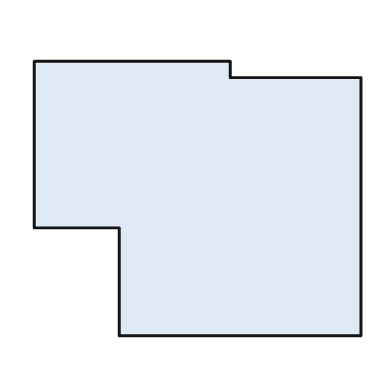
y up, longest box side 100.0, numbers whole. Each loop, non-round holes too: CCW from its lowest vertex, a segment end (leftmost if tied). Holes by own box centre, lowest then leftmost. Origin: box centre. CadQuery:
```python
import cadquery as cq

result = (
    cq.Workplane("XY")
    .moveTo(-24.0, -42.0)
    .lineTo(50.0, -42.0)
    .lineTo(50.0, 37.0)
    .lineTo(10.0, 37.0)
    .lineTo(10.0, 42.0)
    .lineTo(-50.0, 42.0)
    .lineTo(-50.0, -9.0)
    .lineTo(-24.0, -9.0)
    .close()
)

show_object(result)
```